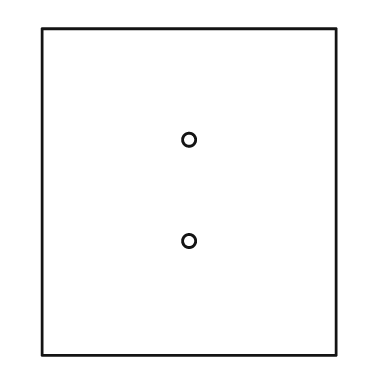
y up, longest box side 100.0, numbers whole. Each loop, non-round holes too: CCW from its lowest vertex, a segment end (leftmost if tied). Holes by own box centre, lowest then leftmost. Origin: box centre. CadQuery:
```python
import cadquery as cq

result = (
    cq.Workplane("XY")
    .moveTo(-45.0, -50.0)
    .lineTo(45.0, -50.0)
    .lineTo(45.0, 50.0)
    .lineTo(-45.0, 50.0)
    .close()
    .moveTo(0.0, -15.0)
    .circle(2.0)
    .moveTo(0.0, 16.0)
    .circle(2.0)
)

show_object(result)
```